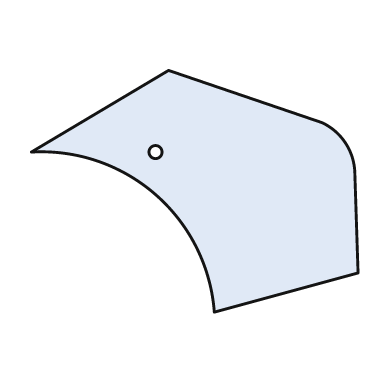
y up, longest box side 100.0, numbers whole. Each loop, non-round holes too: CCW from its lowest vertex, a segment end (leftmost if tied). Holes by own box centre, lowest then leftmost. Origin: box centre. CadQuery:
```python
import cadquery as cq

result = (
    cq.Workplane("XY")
    .moveTo(6.0, -37.0)
    .lineTo(50.0, -25.0)
    .lineTo(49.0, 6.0)
    .threePointArc((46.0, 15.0), (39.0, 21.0))
    .lineTo(-8.0, 37.0)
    .lineTo(-50.0, 12.0)
    .threePointArc((-12.0, -1.0), (6.0, -37.0))
    .close()
    .moveTo(-12.0, 12.0)
    .circle(2.0)
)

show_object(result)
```